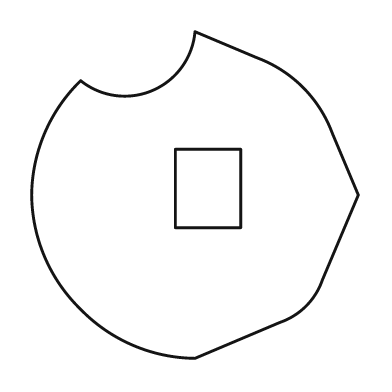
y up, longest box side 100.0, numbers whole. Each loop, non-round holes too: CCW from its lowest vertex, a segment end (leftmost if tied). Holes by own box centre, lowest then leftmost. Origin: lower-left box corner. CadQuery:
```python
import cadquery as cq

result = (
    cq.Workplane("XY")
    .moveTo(50.0, 0.0)
    .lineTo(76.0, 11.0)
    .threePointArc((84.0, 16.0), (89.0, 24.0))
    .lineTo(100.0, 50.0)
    .lineTo(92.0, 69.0)
    .threePointArc((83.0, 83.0), (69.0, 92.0))
    .lineTo(50.0, 100.0)
    .threePointArc((37.0, 82.0), (15.0, 85.0))
    .threePointArc((4.0, 69.0), (0.0, 50.0))
    .threePointArc((4.0, 31.0), (15.0, 15.0))
    .threePointArc((31.0, 4.0), (50.0, 0.0))
    .close()
    .moveTo(44.0, 40.0)
    .lineTo(64.0, 40.0)
    .lineTo(64.0, 64.0)
    .lineTo(44.0, 64.0)
    .close()
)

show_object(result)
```